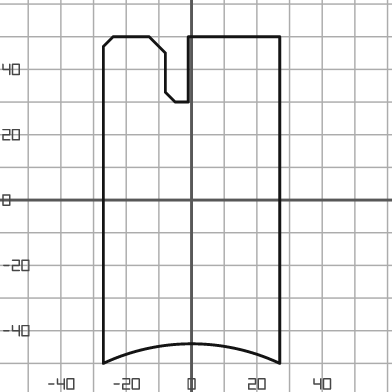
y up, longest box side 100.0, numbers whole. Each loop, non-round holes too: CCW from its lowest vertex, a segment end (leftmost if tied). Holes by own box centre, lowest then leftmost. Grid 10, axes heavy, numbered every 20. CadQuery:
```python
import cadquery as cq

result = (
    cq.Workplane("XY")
    .moveTo(-27.0, -50.0)
    .threePointArc((0.0, -44.0), (27.0, -50.0))
    .lineTo(27.0, 50.0)
    .lineTo(-1.0, 50.0)
    .lineTo(-1.0, 30.0)
    .lineTo(-5.0, 30.0)
    .lineTo(-8.0, 33.0)
    .lineTo(-8.0, 45.0)
    .lineTo(-13.0, 50.0)
    .lineTo(-24.0, 50.0)
    .lineTo(-27.0, 47.0)
    .close()
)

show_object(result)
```